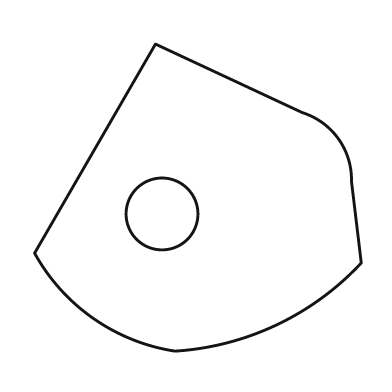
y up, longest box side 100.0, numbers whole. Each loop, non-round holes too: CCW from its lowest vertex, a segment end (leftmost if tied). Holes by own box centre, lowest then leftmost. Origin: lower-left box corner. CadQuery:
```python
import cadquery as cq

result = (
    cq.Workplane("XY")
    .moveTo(43.0, 0.0)
    .threePointArc((74.0, 8.0), (100.0, 27.0))
    .lineTo(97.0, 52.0)
    .threePointArc((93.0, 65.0), (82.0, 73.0))
    .lineTo(37.0, 94.0)
    .lineTo(0.0, 30.0)
    .threePointArc((18.0, 10.0), (43.0, 0.0))
    .close()
    .moveTo(39.0, 42.0)
    .circle(11.0)
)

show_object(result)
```